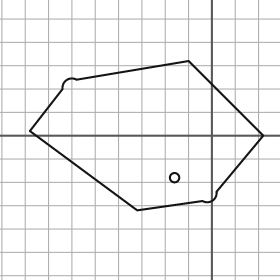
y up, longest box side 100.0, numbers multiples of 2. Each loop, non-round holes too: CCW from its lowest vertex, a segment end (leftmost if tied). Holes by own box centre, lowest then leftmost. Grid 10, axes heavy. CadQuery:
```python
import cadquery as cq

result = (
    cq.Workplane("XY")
    .moveTo(-32.0, -32.0)
    .lineTo(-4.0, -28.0)
    .threePointArc((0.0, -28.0), (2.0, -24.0))
    .lineTo(22.0, 0.0)
    .lineTo(-10.0, 32.0)
    .lineTo(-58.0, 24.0)
    .threePointArc((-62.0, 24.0), (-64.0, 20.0))
    .lineTo(-78.0, 2.0)
    .close()
    .moveTo(-16.0, -18.0)
    .circle(2.0)
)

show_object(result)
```